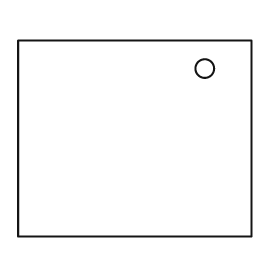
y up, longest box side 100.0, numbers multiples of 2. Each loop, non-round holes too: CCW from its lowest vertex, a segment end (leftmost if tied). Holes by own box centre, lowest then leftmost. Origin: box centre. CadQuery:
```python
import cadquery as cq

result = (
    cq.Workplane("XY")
    .moveTo(-50.0, -42.0)
    .lineTo(50.0, -42.0)
    .lineTo(50.0, 42.0)
    .lineTo(-50.0, 42.0)
    .close()
    .moveTo(30.0, 30.0)
    .circle(4.0)
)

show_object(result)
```